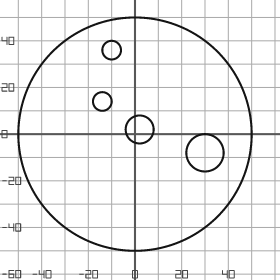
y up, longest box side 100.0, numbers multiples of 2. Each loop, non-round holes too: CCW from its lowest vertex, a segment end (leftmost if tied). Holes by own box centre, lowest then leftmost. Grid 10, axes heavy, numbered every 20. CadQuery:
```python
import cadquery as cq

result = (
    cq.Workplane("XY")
    .moveTo(0.0, 0.0)
    .circle(50.0)
    .moveTo(30.0, -8.0)
    .circle(8.0)
    .moveTo(2.0, 2.0)
    .circle(6.0)
    .moveTo(-14.0, 14.0)
    .circle(4.0)
    .moveTo(-10.0, 36.0)
    .circle(4.0)
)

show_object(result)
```